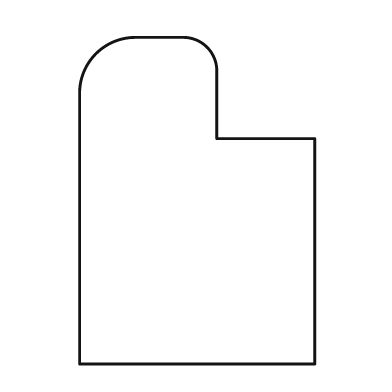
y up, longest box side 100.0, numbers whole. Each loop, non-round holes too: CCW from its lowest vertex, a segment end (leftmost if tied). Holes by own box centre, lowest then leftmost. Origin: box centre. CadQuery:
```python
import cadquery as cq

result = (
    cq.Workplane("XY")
    .moveTo(-36.0, -50.0)
    .lineTo(36.0, -50.0)
    .lineTo(36.0, 19.0)
    .lineTo(6.0, 19.0)
    .lineTo(6.0, 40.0)
    .threePointArc((3.0, 47.0), (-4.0, 50.0))
    .lineTo(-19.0, 50.0)
    .threePointArc((-31.0, 45.0), (-36.0, 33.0))
    .close()
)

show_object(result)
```